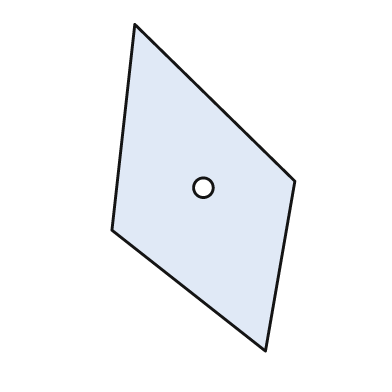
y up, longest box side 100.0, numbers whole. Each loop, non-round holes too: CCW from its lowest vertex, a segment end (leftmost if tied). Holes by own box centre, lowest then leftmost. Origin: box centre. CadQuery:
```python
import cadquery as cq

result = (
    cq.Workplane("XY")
    .moveTo(19.0, -50.0)
    .lineTo(28.0, 2.0)
    .lineTo(-21.0, 50.0)
    .lineTo(-28.0, -13.0)
    .close()
    .moveTo(0.0, 0.0)
    .circle(3.0)
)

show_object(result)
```